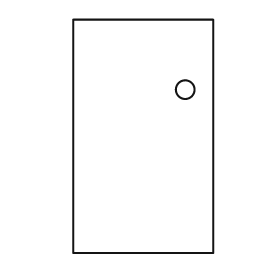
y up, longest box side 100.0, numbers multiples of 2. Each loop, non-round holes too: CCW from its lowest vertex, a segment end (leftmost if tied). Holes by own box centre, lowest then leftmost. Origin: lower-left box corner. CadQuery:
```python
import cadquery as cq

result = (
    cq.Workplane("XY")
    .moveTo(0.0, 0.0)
    .lineTo(60.0, 0.0)
    .lineTo(60.0, 100.0)
    .lineTo(0.0, 100.0)
    .close()
    .moveTo(48.0, 70.0)
    .circle(4.0)
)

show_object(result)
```